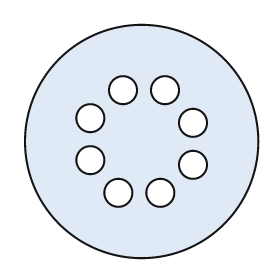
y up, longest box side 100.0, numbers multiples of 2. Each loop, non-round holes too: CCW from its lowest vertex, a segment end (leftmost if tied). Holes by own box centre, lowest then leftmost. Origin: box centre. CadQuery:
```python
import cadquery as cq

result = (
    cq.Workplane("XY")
    .moveTo(0.0, 0.0)
    .circle(50.0)
    .moveTo(-10.0, -22.0)
    .circle(6.0)
    .moveTo(8.0, -22.0)
    .circle(6.0)
    .moveTo(22.0, -10.0)
    .circle(6.0)
    .moveTo(-22.0, -8.0)
    .circle(6.0)
    .moveTo(22.0, 8.0)
    .circle(6.0)
    .moveTo(-22.0, 10.0)
    .circle(6.0)
    .moveTo(-8.0, 22.0)
    .circle(6.0)
    .moveTo(10.0, 22.0)
    .circle(6.0)
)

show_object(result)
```